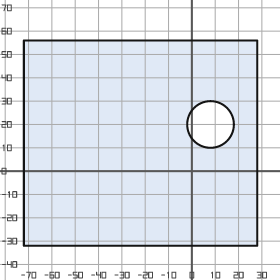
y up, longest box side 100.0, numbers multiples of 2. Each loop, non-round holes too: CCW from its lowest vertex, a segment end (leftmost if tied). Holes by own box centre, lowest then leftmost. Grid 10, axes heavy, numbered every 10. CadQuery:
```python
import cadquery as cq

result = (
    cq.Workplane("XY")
    .moveTo(-72.0, -32.0)
    .lineTo(28.0, -32.0)
    .lineTo(28.0, 56.0)
    .lineTo(-72.0, 56.0)
    .close()
    .moveTo(8.0, 20.0)
    .circle(10.0)
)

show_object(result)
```